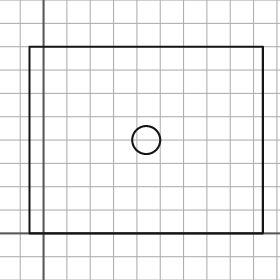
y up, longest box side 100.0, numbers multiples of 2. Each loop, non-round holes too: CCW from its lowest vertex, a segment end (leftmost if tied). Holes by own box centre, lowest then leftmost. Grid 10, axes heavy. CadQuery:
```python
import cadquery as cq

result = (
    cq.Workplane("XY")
    .moveTo(-6.0, 0.0)
    .lineTo(94.0, 0.0)
    .lineTo(94.0, 80.0)
    .lineTo(-6.0, 80.0)
    .close()
    .moveTo(44.0, 40.0)
    .circle(6.0)
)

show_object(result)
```